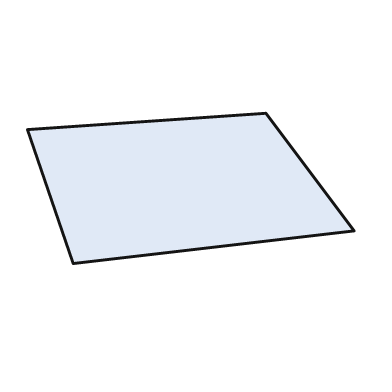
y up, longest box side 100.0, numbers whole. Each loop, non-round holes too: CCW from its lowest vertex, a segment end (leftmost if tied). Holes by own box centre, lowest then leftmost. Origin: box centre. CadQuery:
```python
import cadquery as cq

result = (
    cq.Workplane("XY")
    .moveTo(-36.0, -23.0)
    .lineTo(50.0, -13.0)
    .lineTo(23.0, 23.0)
    .lineTo(-50.0, 18.0)
    .close()
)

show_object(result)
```